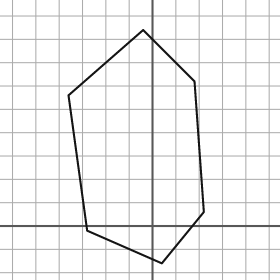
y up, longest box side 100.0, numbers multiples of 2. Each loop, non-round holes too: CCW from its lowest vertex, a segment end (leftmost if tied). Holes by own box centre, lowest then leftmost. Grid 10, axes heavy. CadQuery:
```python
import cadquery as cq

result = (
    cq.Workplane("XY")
    .moveTo(4.0, -16.0)
    .lineTo(22.0, 6.0)
    .lineTo(18.0, 62.0)
    .lineTo(-4.0, 84.0)
    .lineTo(-36.0, 56.0)
    .lineTo(-28.0, -2.0)
    .close()
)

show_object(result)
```